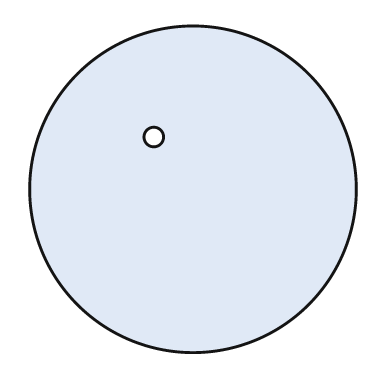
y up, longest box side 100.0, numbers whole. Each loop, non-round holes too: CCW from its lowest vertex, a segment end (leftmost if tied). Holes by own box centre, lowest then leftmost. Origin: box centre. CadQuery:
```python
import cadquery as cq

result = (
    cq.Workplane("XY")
    .moveTo(0.0, 0.0)
    .circle(50.0)
    .moveTo(-12.0, 16.0)
    .circle(3.0)
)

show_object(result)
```